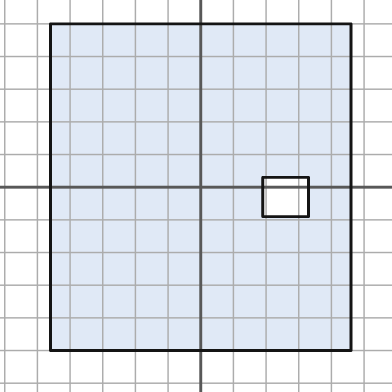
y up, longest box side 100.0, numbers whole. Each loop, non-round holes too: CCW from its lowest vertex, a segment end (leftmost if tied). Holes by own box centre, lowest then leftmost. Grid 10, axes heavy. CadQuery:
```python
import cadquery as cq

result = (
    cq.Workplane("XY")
    .moveTo(-46.0, -50.0)
    .lineTo(46.0, -50.0)
    .lineTo(46.0, 50.0)
    .lineTo(-46.0, 50.0)
    .close()
    .moveTo(19.0, -9.0)
    .lineTo(33.0, -9.0)
    .lineTo(33.0, 3.0)
    .lineTo(19.0, 3.0)
    .close()
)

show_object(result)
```